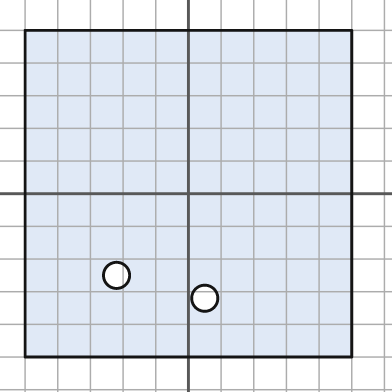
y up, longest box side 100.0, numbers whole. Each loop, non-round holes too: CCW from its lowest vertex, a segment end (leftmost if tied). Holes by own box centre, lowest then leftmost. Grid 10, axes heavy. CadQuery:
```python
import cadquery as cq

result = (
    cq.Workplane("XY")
    .moveTo(-50.0, -50.0)
    .lineTo(50.0, -50.0)
    .lineTo(50.0, 50.0)
    .lineTo(-50.0, 50.0)
    .close()
    .moveTo(5.0, -32.0)
    .circle(4.0)
    .moveTo(-22.0, -25.0)
    .circle(4.0)
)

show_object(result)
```